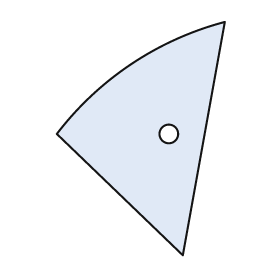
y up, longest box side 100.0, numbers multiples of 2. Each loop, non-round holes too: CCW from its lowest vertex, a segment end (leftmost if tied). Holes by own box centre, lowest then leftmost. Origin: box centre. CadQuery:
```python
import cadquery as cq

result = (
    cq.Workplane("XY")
    .moveTo(18.0, -50.0)
    .lineTo(36.0, 50.0)
    .threePointArc((-4.0, 32.0), (-36.0, 2.0))
    .close()
    .moveTo(12.0, 2.0)
    .circle(4.0)
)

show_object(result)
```